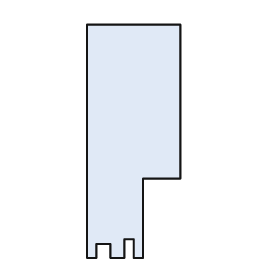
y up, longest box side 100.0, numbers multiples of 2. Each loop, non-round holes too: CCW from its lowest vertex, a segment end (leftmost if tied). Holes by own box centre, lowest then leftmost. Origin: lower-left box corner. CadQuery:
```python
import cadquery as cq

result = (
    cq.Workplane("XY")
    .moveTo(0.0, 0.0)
    .lineTo(4.0, 0.0)
    .lineTo(4.0, 6.0)
    .lineTo(10.0, 6.0)
    .lineTo(10.0, 0.0)
    .lineTo(16.0, 0.0)
    .lineTo(16.0, 8.0)
    .lineTo(20.0, 8.0)
    .lineTo(20.0, 0.0)
    .lineTo(24.0, 0.0)
    .lineTo(24.0, 34.0)
    .lineTo(40.0, 34.0)
    .lineTo(40.0, 100.0)
    .lineTo(0.0, 100.0)
    .close()
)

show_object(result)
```